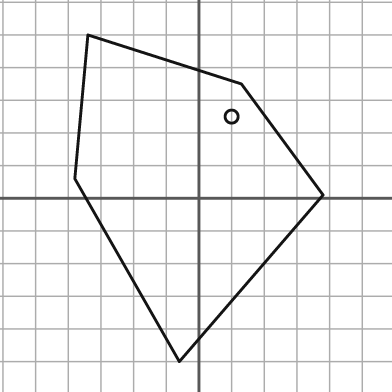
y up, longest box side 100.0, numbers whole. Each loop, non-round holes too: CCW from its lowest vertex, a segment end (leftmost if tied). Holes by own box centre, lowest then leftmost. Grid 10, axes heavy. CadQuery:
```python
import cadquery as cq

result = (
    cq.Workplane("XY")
    .moveTo(-6.0, -50.0)
    .lineTo(38.0, 1.0)
    .lineTo(13.0, 35.0)
    .lineTo(-34.0, 50.0)
    .lineTo(-38.0, 6.0)
    .close()
    .moveTo(10.0, 25.0)
    .circle(2.0)
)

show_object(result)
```